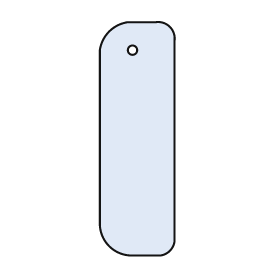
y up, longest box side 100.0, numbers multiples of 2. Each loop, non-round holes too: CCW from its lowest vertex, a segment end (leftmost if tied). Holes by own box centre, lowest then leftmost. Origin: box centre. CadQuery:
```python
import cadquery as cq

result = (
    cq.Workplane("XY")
    .moveTo(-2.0, -50.0)
    .lineTo(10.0, -50.0)
    .threePointArc((14.0, -48.0), (16.0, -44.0))
    .lineTo(16.0, 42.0)
    .threePointArc((14.0, 48.0), (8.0, 50.0))
    .lineTo(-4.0, 50.0)
    .threePointArc((-12.0, 46.0), (-16.0, 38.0))
    .lineTo(-16.0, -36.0)
    .threePointArc((-12.0, -46.0), (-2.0, -50.0))
    .close()
    .moveTo(-2.0, 38.0)
    .circle(2.0)
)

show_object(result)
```